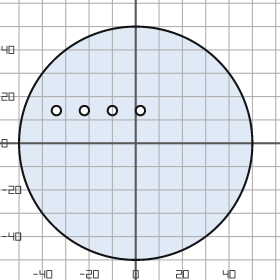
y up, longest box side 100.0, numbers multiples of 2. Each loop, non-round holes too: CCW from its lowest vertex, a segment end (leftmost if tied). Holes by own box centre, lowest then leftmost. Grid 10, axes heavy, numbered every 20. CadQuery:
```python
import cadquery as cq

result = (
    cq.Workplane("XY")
    .moveTo(0.0, 0.0)
    .circle(50.0)
    .moveTo(-34.0, 14.0)
    .circle(2.0)
    .moveTo(-22.0, 14.0)
    .circle(2.0)
    .moveTo(-10.0, 14.0)
    .circle(2.0)
    .moveTo(2.0, 14.0)
    .circle(2.0)
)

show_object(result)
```